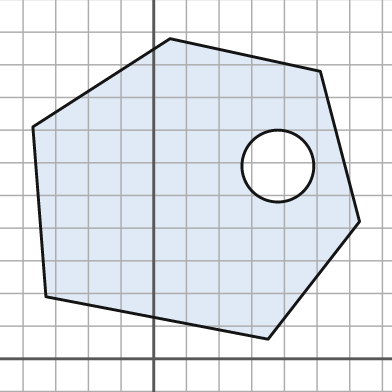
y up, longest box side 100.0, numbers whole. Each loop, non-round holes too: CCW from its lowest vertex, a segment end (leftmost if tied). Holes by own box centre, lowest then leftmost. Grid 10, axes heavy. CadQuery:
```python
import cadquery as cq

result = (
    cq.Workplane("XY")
    .moveTo(35.0, 6.0)
    .lineTo(63.0, 42.0)
    .lineTo(51.0, 88.0)
    .lineTo(5.0, 98.0)
    .lineTo(-37.0, 71.0)
    .lineTo(-33.0, 19.0)
    .close()
    .moveTo(38.0, 59.0)
    .circle(11.0)
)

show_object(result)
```